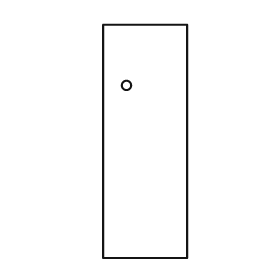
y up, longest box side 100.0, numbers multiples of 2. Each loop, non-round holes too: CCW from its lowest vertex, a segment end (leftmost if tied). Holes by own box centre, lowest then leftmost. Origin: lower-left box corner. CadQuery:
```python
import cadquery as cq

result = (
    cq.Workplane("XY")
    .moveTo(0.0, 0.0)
    .lineTo(36.0, 0.0)
    .lineTo(36.0, 100.0)
    .lineTo(0.0, 100.0)
    .close()
    .moveTo(10.0, 74.0)
    .circle(2.0)
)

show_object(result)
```